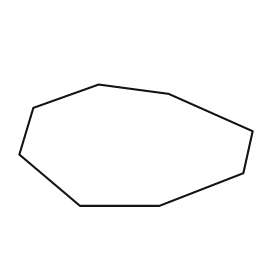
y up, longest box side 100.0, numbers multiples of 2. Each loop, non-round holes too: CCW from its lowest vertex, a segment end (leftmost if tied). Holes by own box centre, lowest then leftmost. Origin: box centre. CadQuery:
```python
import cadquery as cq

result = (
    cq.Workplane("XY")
    .moveTo(-24.0, -26.0)
    .lineTo(10.0, -26.0)
    .lineTo(46.0, -12.0)
    .lineTo(50.0, 6.0)
    .lineTo(14.0, 22.0)
    .lineTo(-16.0, 26.0)
    .lineTo(-44.0, 16.0)
    .lineTo(-50.0, -4.0)
    .close()
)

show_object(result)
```